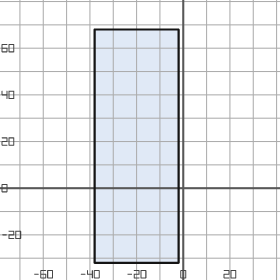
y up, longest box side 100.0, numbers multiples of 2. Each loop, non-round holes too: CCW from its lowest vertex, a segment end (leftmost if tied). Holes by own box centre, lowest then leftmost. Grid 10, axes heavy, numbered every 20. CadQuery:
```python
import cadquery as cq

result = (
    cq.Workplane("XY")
    .moveTo(-38.0, -32.0)
    .lineTo(-2.0, -32.0)
    .lineTo(-2.0, 68.0)
    .lineTo(-38.0, 68.0)
    .close()
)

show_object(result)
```